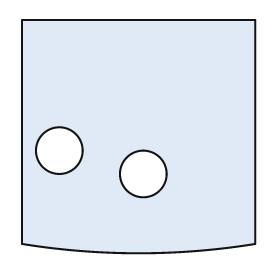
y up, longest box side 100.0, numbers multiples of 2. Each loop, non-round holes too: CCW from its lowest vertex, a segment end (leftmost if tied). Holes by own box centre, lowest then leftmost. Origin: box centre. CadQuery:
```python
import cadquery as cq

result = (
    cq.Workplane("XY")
    .moveTo(-50.0, -46.0)
    .threePointArc((0.0, -50.0), (50.0, -46.0))
    .lineTo(50.0, 50.0)
    .lineTo(-50.0, 50.0)
    .close()
    .moveTo(2.0, -16.0)
    .circle(10.0)
    .moveTo(-34.0, -6.0)
    .circle(10.0)
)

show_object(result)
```